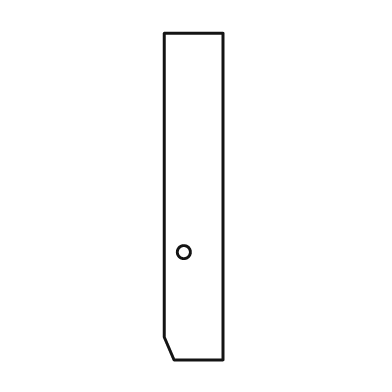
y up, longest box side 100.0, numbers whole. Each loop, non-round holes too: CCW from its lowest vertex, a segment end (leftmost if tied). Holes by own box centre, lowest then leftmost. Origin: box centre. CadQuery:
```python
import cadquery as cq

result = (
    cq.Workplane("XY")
    .moveTo(-6.0, -50.0)
    .lineTo(9.0, -50.0)
    .lineTo(9.0, 50.0)
    .lineTo(-9.0, 50.0)
    .lineTo(-9.0, -43.0)
    .close()
    .moveTo(-3.0, -17.0)
    .circle(2.0)
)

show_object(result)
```